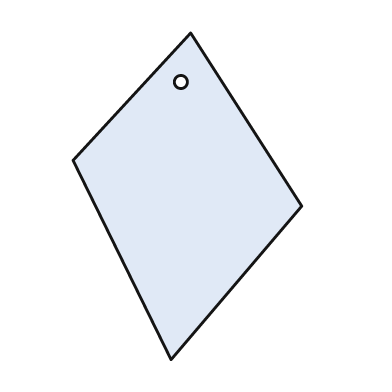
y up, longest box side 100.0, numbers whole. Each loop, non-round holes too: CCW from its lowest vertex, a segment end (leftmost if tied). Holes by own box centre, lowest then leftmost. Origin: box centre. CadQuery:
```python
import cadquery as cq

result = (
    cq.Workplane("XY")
    .moveTo(-5.0, -50.0)
    .lineTo(35.0, -3.0)
    .lineTo(1.0, 50.0)
    .lineTo(-35.0, 11.0)
    .close()
    .moveTo(-2.0, 35.0)
    .circle(2.0)
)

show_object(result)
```